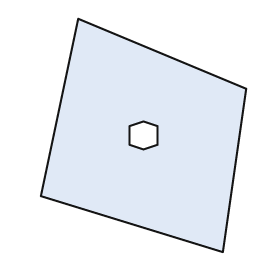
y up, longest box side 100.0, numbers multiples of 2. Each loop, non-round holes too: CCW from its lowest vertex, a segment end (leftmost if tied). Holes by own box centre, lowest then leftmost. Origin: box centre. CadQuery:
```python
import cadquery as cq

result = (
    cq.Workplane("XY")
    .moveTo(34.0, -50.0)
    .lineTo(44.0, 20.0)
    .lineTo(-28.0, 50.0)
    .lineTo(-44.0, -26.0)
    .close()
    .moveTo(0.0, -6.0)
    .lineTo(6.0, -4.0)
    .lineTo(6.0, 4.0)
    .lineTo(0.0, 6.0)
    .lineTo(-6.0, 4.0)
    .lineTo(-6.0, -4.0)
    .close()
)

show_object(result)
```